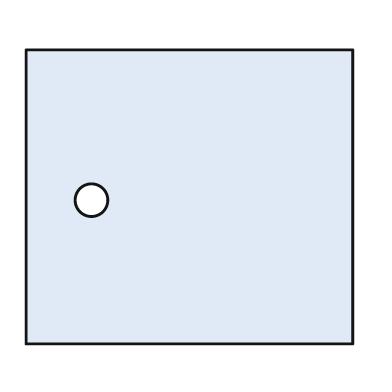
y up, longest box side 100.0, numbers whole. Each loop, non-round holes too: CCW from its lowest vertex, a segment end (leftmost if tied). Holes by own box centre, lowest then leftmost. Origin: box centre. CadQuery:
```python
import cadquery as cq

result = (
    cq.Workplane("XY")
    .moveTo(-50.0, -45.0)
    .lineTo(50.0, -45.0)
    .lineTo(50.0, 45.0)
    .lineTo(-50.0, 45.0)
    .close()
    .moveTo(-30.0, -1.0)
    .circle(5.0)
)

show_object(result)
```